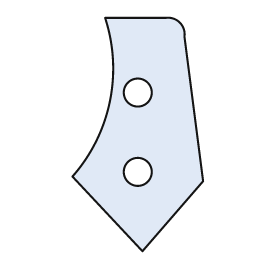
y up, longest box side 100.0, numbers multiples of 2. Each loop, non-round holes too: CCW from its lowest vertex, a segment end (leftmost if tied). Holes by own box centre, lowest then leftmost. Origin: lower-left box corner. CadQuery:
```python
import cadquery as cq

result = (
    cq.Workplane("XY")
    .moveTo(30.0, 0.0)
    .lineTo(56.0, 30.0)
    .lineTo(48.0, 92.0)
    .threePointArc((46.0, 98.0), (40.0, 100.0))
    .lineTo(14.0, 100.0)
    .threePointArc((16.0, 64.0), (0.0, 32.0))
    .close()
    .moveTo(28.0, 34.0)
    .circle(6.0)
    .moveTo(28.0, 68.0)
    .circle(6.0)
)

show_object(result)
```